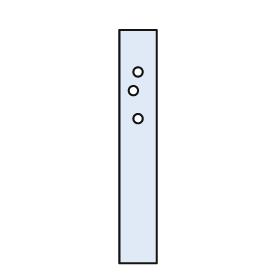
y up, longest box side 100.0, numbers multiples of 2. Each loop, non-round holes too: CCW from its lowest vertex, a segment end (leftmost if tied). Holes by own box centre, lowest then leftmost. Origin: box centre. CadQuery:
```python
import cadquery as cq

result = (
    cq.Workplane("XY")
    .moveTo(-8.0, -50.0)
    .lineTo(8.0, -50.0)
    .lineTo(8.0, 50.0)
    .lineTo(-8.0, 50.0)
    .close()
    .moveTo(0.0, 12.0)
    .circle(2.0)
    .moveTo(-2.0, 24.0)
    .circle(2.0)
    .moveTo(0.0, 32.0)
    .circle(2.0)
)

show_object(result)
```